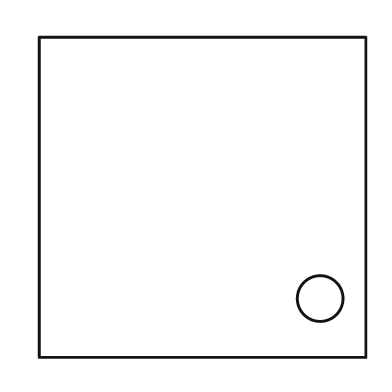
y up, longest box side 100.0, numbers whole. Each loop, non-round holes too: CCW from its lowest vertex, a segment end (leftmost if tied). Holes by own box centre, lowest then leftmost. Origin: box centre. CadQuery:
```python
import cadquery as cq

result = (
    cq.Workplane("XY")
    .moveTo(-50.0, -49.0)
    .lineTo(50.0, -49.0)
    .lineTo(50.0, 49.0)
    .lineTo(-50.0, 49.0)
    .close()
    .moveTo(36.0, -31.0)
    .circle(7.0)
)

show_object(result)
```